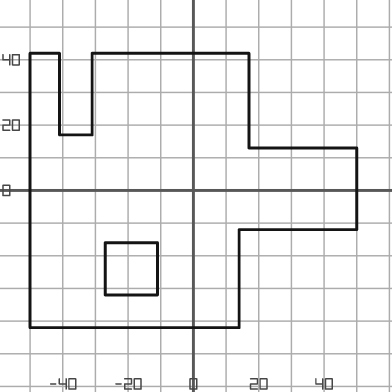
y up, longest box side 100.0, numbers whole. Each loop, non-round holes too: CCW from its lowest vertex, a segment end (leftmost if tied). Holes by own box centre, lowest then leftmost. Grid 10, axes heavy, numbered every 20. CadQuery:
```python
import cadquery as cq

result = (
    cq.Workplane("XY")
    .moveTo(-50.0, -42.0)
    .lineTo(14.0, -42.0)
    .lineTo(14.0, -12.0)
    .lineTo(50.0, -12.0)
    .lineTo(50.0, 13.0)
    .lineTo(17.0, 13.0)
    .lineTo(17.0, 42.0)
    .lineTo(-31.0, 42.0)
    .lineTo(-31.0, 17.0)
    .lineTo(-41.0, 17.0)
    .lineTo(-41.0, 42.0)
    .lineTo(-50.0, 42.0)
    .close()
    .moveTo(-27.0, -32.0)
    .lineTo(-11.0, -32.0)
    .lineTo(-11.0, -16.0)
    .lineTo(-27.0, -16.0)
    .close()
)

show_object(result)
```